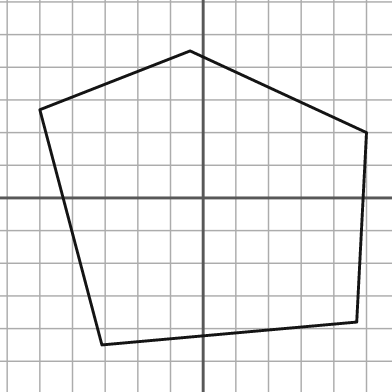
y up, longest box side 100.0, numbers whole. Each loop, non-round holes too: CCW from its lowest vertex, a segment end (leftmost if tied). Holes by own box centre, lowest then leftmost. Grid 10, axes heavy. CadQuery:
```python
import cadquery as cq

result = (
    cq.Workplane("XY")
    .moveTo(-31.0, -45.0)
    .lineTo(47.0, -38.0)
    .lineTo(50.0, 20.0)
    .lineTo(-4.0, 45.0)
    .lineTo(-50.0, 27.0)
    .close()
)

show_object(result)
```